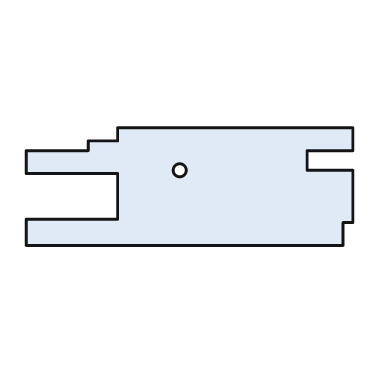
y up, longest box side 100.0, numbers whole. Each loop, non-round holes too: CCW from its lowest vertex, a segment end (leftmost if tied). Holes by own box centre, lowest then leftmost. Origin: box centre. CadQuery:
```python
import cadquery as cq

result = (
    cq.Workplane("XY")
    .moveTo(-50.0, -18.0)
    .lineTo(47.0, -18.0)
    .lineTo(47.0, -11.0)
    .lineTo(50.0, -11.0)
    .lineTo(50.0, 5.0)
    .lineTo(36.0, 5.0)
    .lineTo(36.0, 11.0)
    .lineTo(50.0, 11.0)
    .lineTo(50.0, 18.0)
    .lineTo(-22.0, 18.0)
    .lineTo(-22.0, 14.0)
    .lineTo(-31.0, 14.0)
    .lineTo(-31.0, 11.0)
    .lineTo(-50.0, 11.0)
    .lineTo(-50.0, 4.0)
    .lineTo(-22.0, 4.0)
    .lineTo(-22.0, -10.0)
    .lineTo(-50.0, -10.0)
    .close()
    .moveTo(-3.0, 5.0)
    .circle(2.0)
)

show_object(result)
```